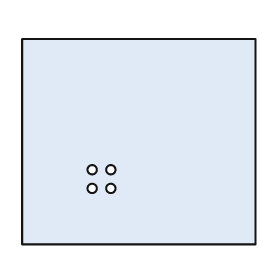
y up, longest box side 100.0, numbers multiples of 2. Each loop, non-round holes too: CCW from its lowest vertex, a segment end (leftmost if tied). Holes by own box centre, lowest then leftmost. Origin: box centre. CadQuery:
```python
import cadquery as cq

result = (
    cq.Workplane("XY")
    .moveTo(-50.0, -44.0)
    .lineTo(50.0, -44.0)
    .lineTo(50.0, 44.0)
    .lineTo(-50.0, 44.0)
    .close()
    .moveTo(-20.0, -20.0)
    .circle(2.0)
    .moveTo(-12.0, -20.0)
    .circle(2.0)
    .moveTo(-20.0, -12.0)
    .circle(2.0)
    .moveTo(-12.0, -12.0)
    .circle(2.0)
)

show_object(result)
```